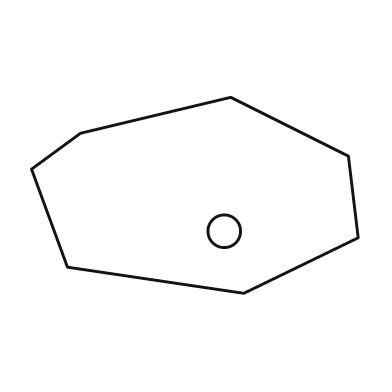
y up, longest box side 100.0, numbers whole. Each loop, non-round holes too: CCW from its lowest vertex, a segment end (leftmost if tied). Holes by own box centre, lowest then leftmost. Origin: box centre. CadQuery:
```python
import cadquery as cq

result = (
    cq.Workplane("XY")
    .moveTo(15.0, -30.0)
    .lineTo(50.0, -13.0)
    .lineTo(47.0, 12.0)
    .lineTo(11.0, 30.0)
    .lineTo(-35.0, 19.0)
    .lineTo(-50.0, 8.0)
    .lineTo(-39.0, -22.0)
    .close()
    .moveTo(9.0, -11.0)
    .circle(5.0)
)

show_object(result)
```